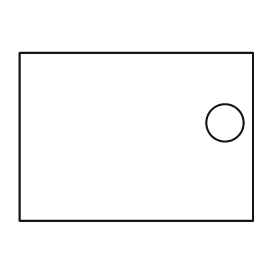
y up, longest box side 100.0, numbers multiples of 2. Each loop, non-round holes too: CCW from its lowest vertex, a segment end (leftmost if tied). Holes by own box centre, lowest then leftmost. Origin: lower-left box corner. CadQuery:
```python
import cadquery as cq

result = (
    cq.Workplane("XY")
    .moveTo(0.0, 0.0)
    .lineTo(100.0, 0.0)
    .lineTo(100.0, 72.0)
    .lineTo(0.0, 72.0)
    .close()
    .moveTo(88.0, 42.0)
    .circle(8.0)
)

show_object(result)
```